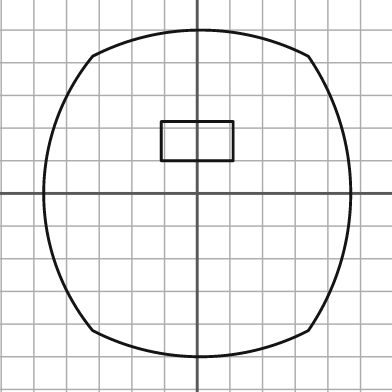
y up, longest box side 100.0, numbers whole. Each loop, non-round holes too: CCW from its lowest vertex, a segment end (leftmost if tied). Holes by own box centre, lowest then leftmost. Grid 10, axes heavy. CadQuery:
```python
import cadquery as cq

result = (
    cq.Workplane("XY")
    .moveTo(-32.0, -42.0)
    .threePointArc((1.0, -50.0), (34.0, -42.0))
    .threePointArc((47.0, 0.0), (34.0, 42.0))
    .threePointArc((1.0, 50.0), (-32.0, 42.0))
    .threePointArc((-47.0, 0.0), (-32.0, -42.0))
    .close()
    .moveTo(-11.0, 10.0)
    .lineTo(11.0, 10.0)
    .lineTo(11.0, 22.0)
    .lineTo(-11.0, 22.0)
    .close()
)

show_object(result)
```